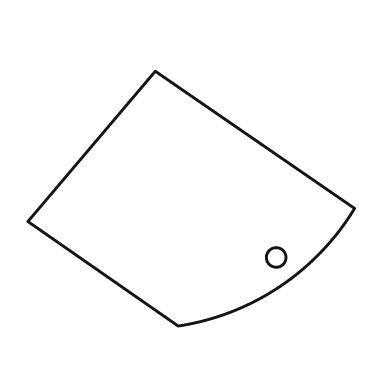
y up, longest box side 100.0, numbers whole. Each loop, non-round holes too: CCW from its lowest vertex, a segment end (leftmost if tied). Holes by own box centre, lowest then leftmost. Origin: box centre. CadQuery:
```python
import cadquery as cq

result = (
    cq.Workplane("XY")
    .moveTo(-4.0, -39.0)
    .threePointArc((27.0, -27.0), (50.0, -3.0))
    .lineTo(-11.0, 39.0)
    .lineTo(-50.0, -7.0)
    .close()
    .moveTo(26.0, -18.0)
    .circle(3.0)
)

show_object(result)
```